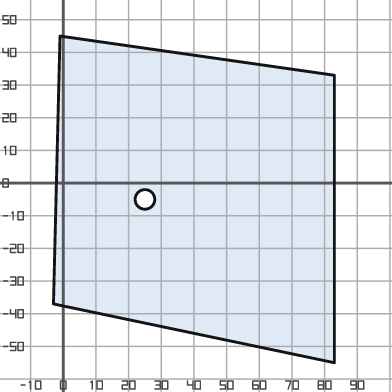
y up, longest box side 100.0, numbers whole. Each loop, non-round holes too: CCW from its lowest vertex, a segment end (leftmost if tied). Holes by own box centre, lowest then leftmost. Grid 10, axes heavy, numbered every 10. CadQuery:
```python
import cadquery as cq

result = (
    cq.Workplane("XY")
    .moveTo(83.0, -55.0)
    .lineTo(83.0, 33.0)
    .lineTo(-1.0, 45.0)
    .lineTo(-3.0, -37.0)
    .close()
    .moveTo(25.0, -5.0)
    .circle(3.0)
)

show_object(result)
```